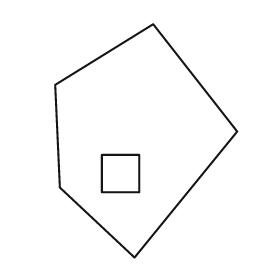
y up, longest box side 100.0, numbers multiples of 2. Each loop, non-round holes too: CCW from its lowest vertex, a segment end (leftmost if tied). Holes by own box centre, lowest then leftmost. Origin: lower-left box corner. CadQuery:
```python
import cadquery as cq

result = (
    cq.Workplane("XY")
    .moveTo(34.0, 0.0)
    .lineTo(78.0, 54.0)
    .lineTo(42.0, 100.0)
    .lineTo(0.0, 74.0)
    .lineTo(2.0, 30.0)
    .close()
    .moveTo(20.0, 28.0)
    .lineTo(36.0, 28.0)
    .lineTo(36.0, 44.0)
    .lineTo(20.0, 44.0)
    .close()
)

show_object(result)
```